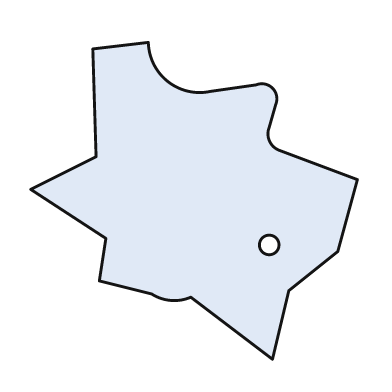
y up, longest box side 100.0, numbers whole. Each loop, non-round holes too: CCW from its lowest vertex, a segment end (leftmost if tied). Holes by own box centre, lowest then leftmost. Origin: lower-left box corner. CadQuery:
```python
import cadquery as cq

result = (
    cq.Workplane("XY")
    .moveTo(74.0, 0.0)
    .lineTo(79.0, 21.0)
    .lineTo(94.0, 33.0)
    .lineTo(100.0, 55.0)
    .lineTo(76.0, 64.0)
    .threePointArc((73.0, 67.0), (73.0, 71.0))
    .lineTo(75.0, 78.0)
    .threePointArc((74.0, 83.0), (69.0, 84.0))
    .lineTo(55.0, 82.0)
    .threePointArc((42.0, 85.0), (36.0, 97.0))
    .lineTo(19.0, 95.0)
    .lineTo(20.0, 62.0)
    .lineTo(0.0, 52.0)
    .lineTo(23.0, 37.0)
    .lineTo(21.0, 24.0)
    .lineTo(37.0, 20.0)
    .threePointArc((43.0, 18.0), (49.0, 19.0))
    .close()
    .moveTo(73.0, 35.0)
    .circle(3.0)
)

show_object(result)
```